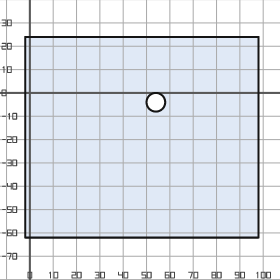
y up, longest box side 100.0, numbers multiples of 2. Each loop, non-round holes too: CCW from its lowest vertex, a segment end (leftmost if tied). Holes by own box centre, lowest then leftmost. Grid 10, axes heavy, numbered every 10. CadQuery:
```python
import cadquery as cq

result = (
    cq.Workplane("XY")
    .moveTo(-2.0, -62.0)
    .lineTo(98.0, -62.0)
    .lineTo(98.0, 24.0)
    .lineTo(-2.0, 24.0)
    .close()
    .moveTo(54.0, -4.0)
    .circle(4.0)
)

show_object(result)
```